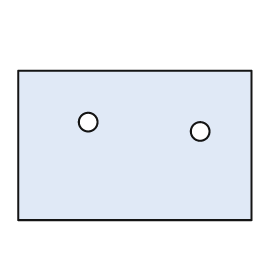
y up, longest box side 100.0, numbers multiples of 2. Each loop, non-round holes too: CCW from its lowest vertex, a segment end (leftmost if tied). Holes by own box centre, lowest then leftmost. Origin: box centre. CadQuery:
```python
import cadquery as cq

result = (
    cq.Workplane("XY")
    .moveTo(-50.0, -32.0)
    .lineTo(50.0, -32.0)
    .lineTo(50.0, 32.0)
    .lineTo(-50.0, 32.0)
    .close()
    .moveTo(28.0, 6.0)
    .circle(4.0)
    .moveTo(-20.0, 10.0)
    .circle(4.0)
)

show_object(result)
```